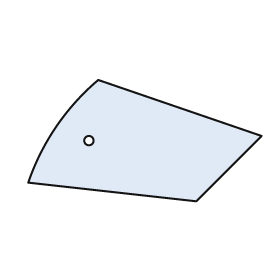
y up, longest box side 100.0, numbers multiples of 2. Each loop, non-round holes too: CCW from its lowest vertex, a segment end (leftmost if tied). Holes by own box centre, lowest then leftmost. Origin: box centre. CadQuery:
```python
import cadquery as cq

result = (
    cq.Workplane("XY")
    .moveTo(22.0, -26.0)
    .lineTo(50.0, 2.0)
    .lineTo(-20.0, 26.0)
    .threePointArc((-38.0, 6.0), (-50.0, -18.0))
    .close()
    .moveTo(-24.0, 0.0)
    .circle(2.0)
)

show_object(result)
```